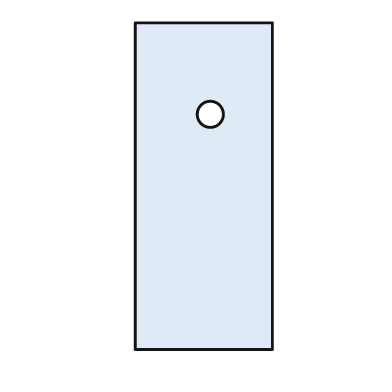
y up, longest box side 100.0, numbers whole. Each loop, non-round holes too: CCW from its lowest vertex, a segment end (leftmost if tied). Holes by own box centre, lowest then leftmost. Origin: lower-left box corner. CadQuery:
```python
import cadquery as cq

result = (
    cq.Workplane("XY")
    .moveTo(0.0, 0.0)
    .lineTo(42.0, 0.0)
    .lineTo(42.0, 100.0)
    .lineTo(0.0, 100.0)
    .close()
    .moveTo(23.0, 72.0)
    .circle(4.0)
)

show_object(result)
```